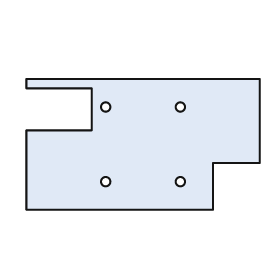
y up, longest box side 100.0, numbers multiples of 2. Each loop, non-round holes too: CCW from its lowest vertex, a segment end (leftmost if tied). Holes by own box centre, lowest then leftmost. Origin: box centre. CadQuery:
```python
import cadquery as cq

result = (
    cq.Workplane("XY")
    .moveTo(-50.0, -28.0)
    .lineTo(30.0, -28.0)
    .lineTo(30.0, -8.0)
    .lineTo(50.0, -8.0)
    .lineTo(50.0, 28.0)
    .lineTo(-50.0, 28.0)
    .lineTo(-50.0, 24.0)
    .lineTo(-22.0, 24.0)
    .lineTo(-22.0, 6.0)
    .lineTo(-50.0, 6.0)
    .close()
    .moveTo(-16.0, -16.0)
    .circle(2.0)
    .moveTo(16.0, -16.0)
    .circle(2.0)
    .moveTo(-16.0, 16.0)
    .circle(2.0)
    .moveTo(16.0, 16.0)
    .circle(2.0)
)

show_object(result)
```